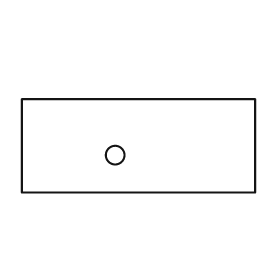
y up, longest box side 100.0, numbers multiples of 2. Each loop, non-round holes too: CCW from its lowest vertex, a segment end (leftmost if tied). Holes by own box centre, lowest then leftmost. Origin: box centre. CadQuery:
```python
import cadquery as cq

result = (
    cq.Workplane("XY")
    .moveTo(-50.0, -20.0)
    .lineTo(50.0, -20.0)
    .lineTo(50.0, 20.0)
    .lineTo(-50.0, 20.0)
    .close()
    .moveTo(-10.0, -4.0)
    .circle(4.0)
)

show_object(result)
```